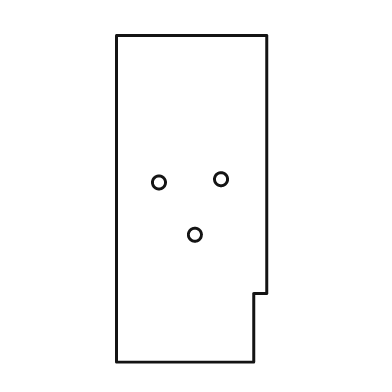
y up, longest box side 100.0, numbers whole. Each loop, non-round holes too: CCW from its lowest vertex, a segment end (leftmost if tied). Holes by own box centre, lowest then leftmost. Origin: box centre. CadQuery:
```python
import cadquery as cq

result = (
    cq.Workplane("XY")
    .moveTo(-23.0, -50.0)
    .lineTo(19.0, -50.0)
    .lineTo(19.0, -29.0)
    .lineTo(23.0, -29.0)
    .lineTo(23.0, 50.0)
    .lineTo(-23.0, 50.0)
    .close()
    .moveTo(1.0, -11.0)
    .circle(2.0)
    .moveTo(-10.0, 5.0)
    .circle(2.0)
    .moveTo(9.0, 6.0)
    .circle(2.0)
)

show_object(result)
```